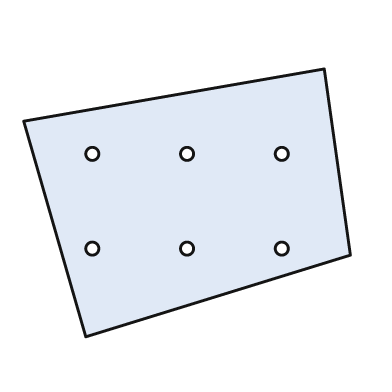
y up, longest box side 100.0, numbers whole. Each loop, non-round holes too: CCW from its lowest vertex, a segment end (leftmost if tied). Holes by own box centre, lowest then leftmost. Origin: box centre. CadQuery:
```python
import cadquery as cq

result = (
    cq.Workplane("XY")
    .moveTo(-31.0, -41.0)
    .lineTo(50.0, -16.0)
    .lineTo(42.0, 41.0)
    .lineTo(-50.0, 25.0)
    .close()
    .moveTo(-29.0, -14.0)
    .circle(2.0)
    .moveTo(0.0, -14.0)
    .circle(2.0)
    .moveTo(29.0, -14.0)
    .circle(2.0)
    .moveTo(-29.0, 15.0)
    .circle(2.0)
    .moveTo(0.0, 15.0)
    .circle(2.0)
    .moveTo(29.0, 15.0)
    .circle(2.0)
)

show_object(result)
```